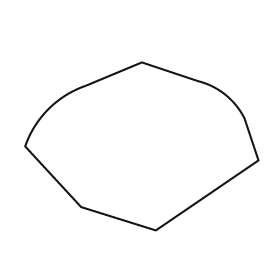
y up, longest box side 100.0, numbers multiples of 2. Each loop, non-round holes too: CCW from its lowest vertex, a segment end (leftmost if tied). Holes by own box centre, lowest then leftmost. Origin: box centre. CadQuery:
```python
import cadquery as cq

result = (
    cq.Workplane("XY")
    .moveTo(6.0, -36.0)
    .lineTo(50.0, -6.0)
    .lineTo(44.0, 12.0)
    .threePointArc((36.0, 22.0), (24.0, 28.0))
    .lineTo(0.0, 36.0)
    .lineTo(-24.0, 26.0)
    .threePointArc((-40.0, 16.0), (-50.0, 0.0))
    .lineTo(-26.0, -26.0)
    .close()
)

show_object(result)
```